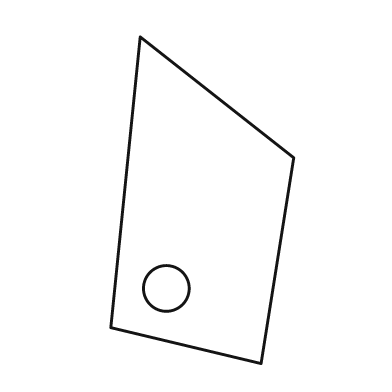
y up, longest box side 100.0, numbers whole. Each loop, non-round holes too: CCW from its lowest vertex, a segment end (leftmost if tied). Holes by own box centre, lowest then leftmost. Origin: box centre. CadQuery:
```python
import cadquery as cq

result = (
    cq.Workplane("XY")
    .moveTo(18.0, -50.0)
    .lineTo(28.0, 13.0)
    .lineTo(-19.0, 50.0)
    .lineTo(-28.0, -39.0)
    .close()
    .moveTo(-11.0, -27.0)
    .circle(7.0)
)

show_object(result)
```